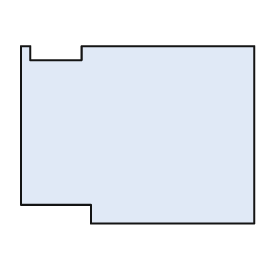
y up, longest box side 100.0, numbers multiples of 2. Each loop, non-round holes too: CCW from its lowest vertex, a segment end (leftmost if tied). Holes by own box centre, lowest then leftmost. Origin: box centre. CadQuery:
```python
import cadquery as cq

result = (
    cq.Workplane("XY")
    .moveTo(-20.0, -38.0)
    .lineTo(50.0, -38.0)
    .lineTo(50.0, 38.0)
    .lineTo(-24.0, 38.0)
    .lineTo(-24.0, 32.0)
    .lineTo(-46.0, 32.0)
    .lineTo(-46.0, 38.0)
    .lineTo(-50.0, 38.0)
    .lineTo(-50.0, -30.0)
    .lineTo(-20.0, -30.0)
    .close()
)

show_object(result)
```